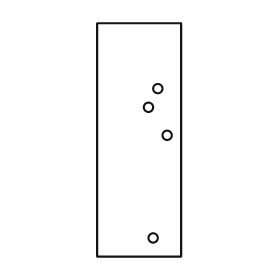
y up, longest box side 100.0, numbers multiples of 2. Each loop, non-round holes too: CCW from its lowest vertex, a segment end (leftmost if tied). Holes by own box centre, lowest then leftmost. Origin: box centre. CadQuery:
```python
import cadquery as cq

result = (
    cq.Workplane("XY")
    .moveTo(-18.0, -50.0)
    .lineTo(18.0, -50.0)
    .lineTo(18.0, 50.0)
    .lineTo(-18.0, 50.0)
    .close()
    .moveTo(6.0, -42.0)
    .circle(2.0)
    .moveTo(12.0, 2.0)
    .circle(2.0)
    .moveTo(4.0, 14.0)
    .circle(2.0)
    .moveTo(8.0, 22.0)
    .circle(2.0)
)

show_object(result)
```